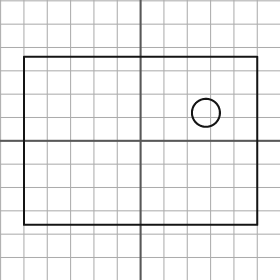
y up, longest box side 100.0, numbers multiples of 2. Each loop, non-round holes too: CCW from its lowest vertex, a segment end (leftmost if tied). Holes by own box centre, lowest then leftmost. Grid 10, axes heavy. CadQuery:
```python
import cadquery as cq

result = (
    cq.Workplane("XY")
    .moveTo(-50.0, -36.0)
    .lineTo(50.0, -36.0)
    .lineTo(50.0, 36.0)
    .lineTo(-50.0, 36.0)
    .close()
    .moveTo(28.0, 12.0)
    .circle(6.0)
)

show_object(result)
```